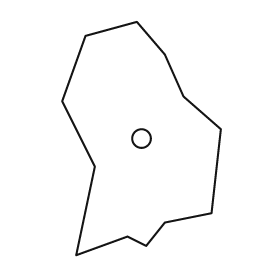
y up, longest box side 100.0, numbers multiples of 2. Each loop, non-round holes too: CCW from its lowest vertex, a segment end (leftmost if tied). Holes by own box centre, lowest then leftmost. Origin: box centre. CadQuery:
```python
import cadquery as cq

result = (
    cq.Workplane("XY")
    .moveTo(-28.0, -50.0)
    .lineTo(-6.0, -42.0)
    .lineTo(2.0, -46.0)
    .lineTo(10.0, -36.0)
    .lineTo(30.0, -32.0)
    .lineTo(34.0, 4.0)
    .lineTo(18.0, 18.0)
    .lineTo(10.0, 36.0)
    .lineTo(-2.0, 50.0)
    .lineTo(-24.0, 44.0)
    .lineTo(-34.0, 16.0)
    .lineTo(-20.0, -12.0)
    .close()
    .moveTo(0.0, 0.0)
    .circle(4.0)
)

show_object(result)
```